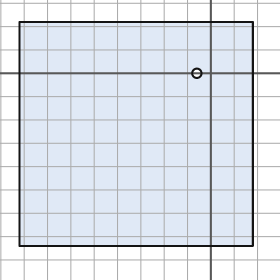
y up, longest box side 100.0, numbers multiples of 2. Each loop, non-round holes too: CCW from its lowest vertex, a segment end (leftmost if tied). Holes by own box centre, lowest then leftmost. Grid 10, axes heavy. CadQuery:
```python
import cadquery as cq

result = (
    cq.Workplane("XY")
    .moveTo(-82.0, -74.0)
    .lineTo(18.0, -74.0)
    .lineTo(18.0, 22.0)
    .lineTo(-82.0, 22.0)
    .close()
    .moveTo(-6.0, 0.0)
    .circle(2.0)
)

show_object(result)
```